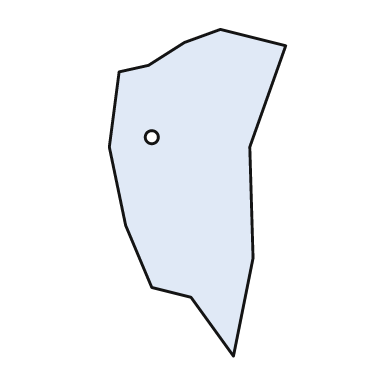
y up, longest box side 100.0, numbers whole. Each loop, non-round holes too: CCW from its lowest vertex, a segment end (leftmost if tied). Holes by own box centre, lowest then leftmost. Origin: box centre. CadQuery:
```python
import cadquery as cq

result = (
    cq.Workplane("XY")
    .moveTo(11.0, -50.0)
    .lineTo(17.0, -20.0)
    .lineTo(16.0, 14.0)
    .lineTo(27.0, 45.0)
    .lineTo(7.0, 50.0)
    .lineTo(-4.0, 46.0)
    .lineTo(-15.0, 39.0)
    .lineTo(-24.0, 37.0)
    .lineTo(-27.0, 14.0)
    .lineTo(-22.0, -10.0)
    .lineTo(-14.0, -29.0)
    .lineTo(-2.0, -32.0)
    .close()
    .moveTo(-14.0, 17.0)
    .circle(2.0)
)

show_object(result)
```